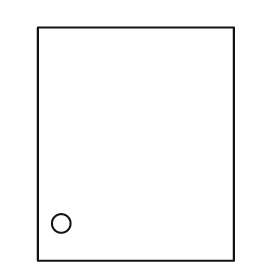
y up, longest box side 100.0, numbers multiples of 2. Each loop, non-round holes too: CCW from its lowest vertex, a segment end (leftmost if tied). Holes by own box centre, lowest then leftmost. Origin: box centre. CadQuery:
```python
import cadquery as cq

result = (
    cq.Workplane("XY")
    .moveTo(-42.0, -50.0)
    .lineTo(42.0, -50.0)
    .lineTo(42.0, 50.0)
    .lineTo(-42.0, 50.0)
    .close()
    .moveTo(-32.0, -34.0)
    .circle(4.0)
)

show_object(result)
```